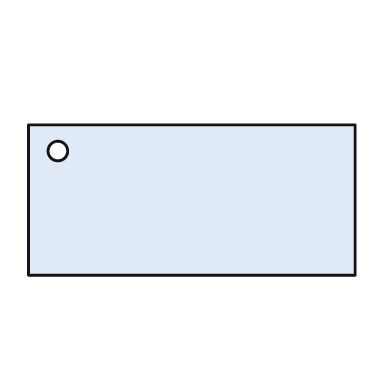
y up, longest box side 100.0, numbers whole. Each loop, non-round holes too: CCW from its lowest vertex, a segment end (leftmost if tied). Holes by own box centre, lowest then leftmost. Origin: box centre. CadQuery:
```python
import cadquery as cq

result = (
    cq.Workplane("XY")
    .moveTo(-50.0, -23.0)
    .lineTo(50.0, -23.0)
    .lineTo(50.0, 23.0)
    .lineTo(-50.0, 23.0)
    .close()
    .moveTo(-41.0, 15.0)
    .circle(3.0)
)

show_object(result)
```